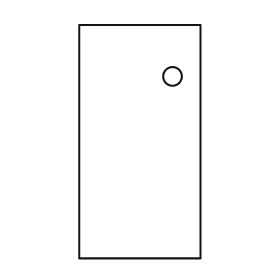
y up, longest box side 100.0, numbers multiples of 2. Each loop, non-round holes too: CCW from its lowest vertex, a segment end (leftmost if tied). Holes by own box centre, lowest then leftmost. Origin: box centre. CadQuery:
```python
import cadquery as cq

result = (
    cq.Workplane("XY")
    .moveTo(-26.0, -50.0)
    .lineTo(26.0, -50.0)
    .lineTo(26.0, 50.0)
    .lineTo(-26.0, 50.0)
    .close()
    .moveTo(14.0, 28.0)
    .circle(4.0)
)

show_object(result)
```